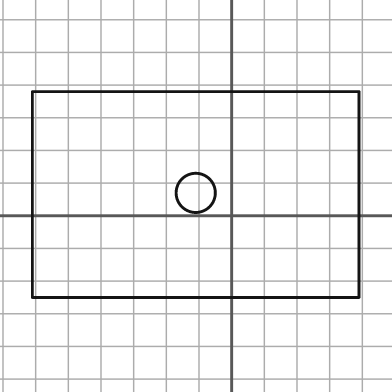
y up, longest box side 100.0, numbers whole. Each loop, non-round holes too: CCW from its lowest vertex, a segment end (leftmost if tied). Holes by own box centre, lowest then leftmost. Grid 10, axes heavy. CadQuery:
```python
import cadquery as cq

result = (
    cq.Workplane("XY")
    .moveTo(-61.0, -25.0)
    .lineTo(39.0, -25.0)
    .lineTo(39.0, 38.0)
    .lineTo(-61.0, 38.0)
    .close()
    .moveTo(-11.0, 7.0)
    .circle(6.0)
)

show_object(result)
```